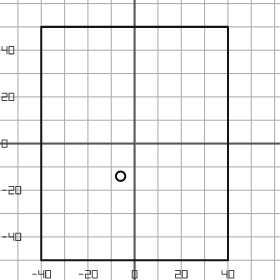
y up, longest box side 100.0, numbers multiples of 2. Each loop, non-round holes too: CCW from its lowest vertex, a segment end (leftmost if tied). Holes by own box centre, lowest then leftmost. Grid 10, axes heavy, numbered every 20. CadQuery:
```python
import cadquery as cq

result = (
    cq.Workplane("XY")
    .moveTo(-40.0, -50.0)
    .lineTo(40.0, -50.0)
    .lineTo(40.0, 50.0)
    .lineTo(-40.0, 50.0)
    .close()
    .moveTo(-6.0, -14.0)
    .circle(2.0)
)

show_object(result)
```